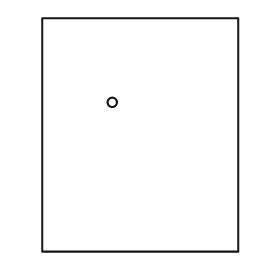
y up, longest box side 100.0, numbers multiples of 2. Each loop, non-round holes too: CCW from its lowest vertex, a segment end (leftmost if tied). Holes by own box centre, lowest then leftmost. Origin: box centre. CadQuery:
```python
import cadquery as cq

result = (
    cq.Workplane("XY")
    .moveTo(-42.0, -50.0)
    .lineTo(42.0, -50.0)
    .lineTo(42.0, 50.0)
    .lineTo(-42.0, 50.0)
    .close()
    .moveTo(-12.0, 14.0)
    .circle(2.0)
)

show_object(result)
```